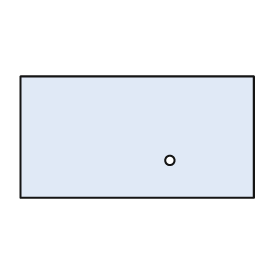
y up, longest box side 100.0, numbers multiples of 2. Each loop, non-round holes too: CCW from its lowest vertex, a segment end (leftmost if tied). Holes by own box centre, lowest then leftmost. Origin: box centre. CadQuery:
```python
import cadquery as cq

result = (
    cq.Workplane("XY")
    .moveTo(-50.0, -26.0)
    .lineTo(50.0, -26.0)
    .lineTo(50.0, 26.0)
    .lineTo(-50.0, 26.0)
    .close()
    .moveTo(14.0, -10.0)
    .circle(2.0)
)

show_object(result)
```